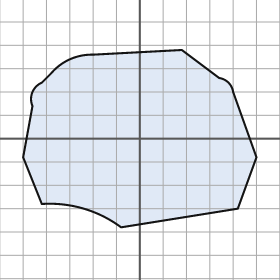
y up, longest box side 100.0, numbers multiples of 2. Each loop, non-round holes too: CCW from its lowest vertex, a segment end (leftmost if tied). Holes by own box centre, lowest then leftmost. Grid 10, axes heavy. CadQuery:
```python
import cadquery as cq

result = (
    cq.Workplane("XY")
    .moveTo(-8.0, -38.0)
    .lineTo(42.0, -30.0)
    .lineTo(50.0, -8.0)
    .lineTo(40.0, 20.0)
    .threePointArc((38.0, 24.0), (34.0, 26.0))
    .lineTo(18.0, 38.0)
    .lineTo(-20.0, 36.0)
    .threePointArc((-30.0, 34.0), (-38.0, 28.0))
    .lineTo(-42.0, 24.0)
    .threePointArc((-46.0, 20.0), (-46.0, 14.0))
    .lineTo(-50.0, -8.0)
    .lineTo(-42.0, -28.0)
    .threePointArc((-24.0, -30.0), (-8.0, -38.0))
    .close()
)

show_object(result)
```